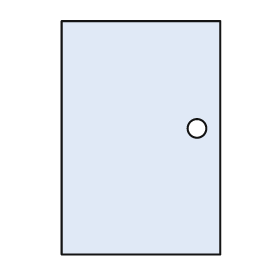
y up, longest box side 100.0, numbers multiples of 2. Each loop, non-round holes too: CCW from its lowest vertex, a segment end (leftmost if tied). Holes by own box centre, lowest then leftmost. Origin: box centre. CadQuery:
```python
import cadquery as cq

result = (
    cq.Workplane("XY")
    .moveTo(-34.0, -50.0)
    .lineTo(34.0, -50.0)
    .lineTo(34.0, 50.0)
    .lineTo(-34.0, 50.0)
    .close()
    .moveTo(24.0, 4.0)
    .circle(4.0)
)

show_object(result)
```